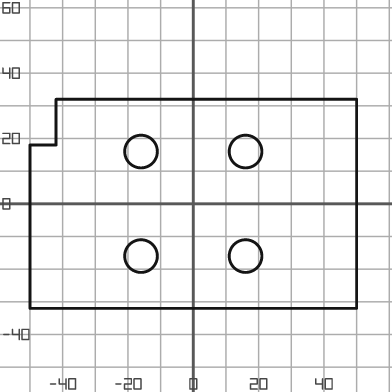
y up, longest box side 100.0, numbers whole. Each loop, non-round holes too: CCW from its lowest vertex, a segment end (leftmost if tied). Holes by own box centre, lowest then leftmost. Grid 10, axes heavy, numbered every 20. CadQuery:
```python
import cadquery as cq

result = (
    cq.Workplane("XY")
    .moveTo(-50.0, -32.0)
    .lineTo(50.0, -32.0)
    .lineTo(50.0, 32.0)
    .lineTo(-42.0, 32.0)
    .lineTo(-42.0, 18.0)
    .lineTo(-50.0, 18.0)
    .close()
    .moveTo(-16.0, -16.0)
    .circle(5.0)
    .moveTo(16.0, -16.0)
    .circle(5.0)
    .moveTo(-16.0, 16.0)
    .circle(5.0)
    .moveTo(16.0, 16.0)
    .circle(5.0)
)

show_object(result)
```